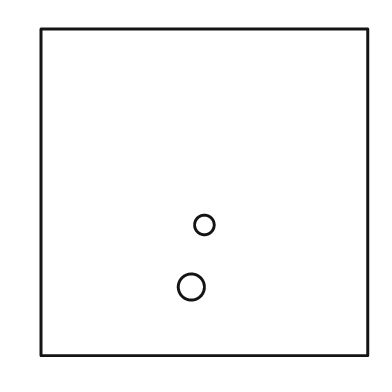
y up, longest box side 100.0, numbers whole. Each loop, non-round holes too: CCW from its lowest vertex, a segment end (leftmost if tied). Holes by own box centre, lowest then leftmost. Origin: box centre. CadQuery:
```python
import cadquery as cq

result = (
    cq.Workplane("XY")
    .moveTo(-50.0, -50.0)
    .lineTo(50.0, -50.0)
    .lineTo(50.0, 50.0)
    .lineTo(-50.0, 50.0)
    .close()
    .moveTo(-4.0, -29.0)
    .circle(4.0)
    .moveTo(0.0, -10.0)
    .circle(3.0)
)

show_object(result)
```